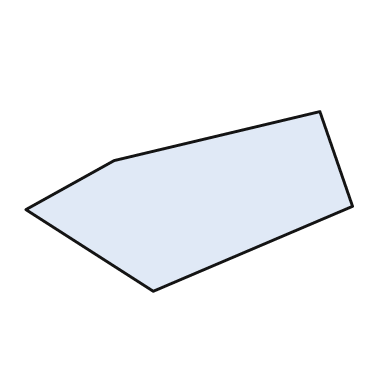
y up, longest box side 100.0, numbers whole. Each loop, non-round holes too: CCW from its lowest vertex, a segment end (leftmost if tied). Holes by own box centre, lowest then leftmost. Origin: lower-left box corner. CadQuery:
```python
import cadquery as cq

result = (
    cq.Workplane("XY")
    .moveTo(39.0, 0.0)
    .lineTo(100.0, 26.0)
    .lineTo(90.0, 55.0)
    .lineTo(27.0, 40.0)
    .lineTo(0.0, 25.0)
    .close()
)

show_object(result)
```